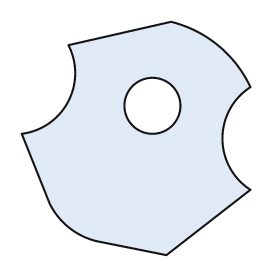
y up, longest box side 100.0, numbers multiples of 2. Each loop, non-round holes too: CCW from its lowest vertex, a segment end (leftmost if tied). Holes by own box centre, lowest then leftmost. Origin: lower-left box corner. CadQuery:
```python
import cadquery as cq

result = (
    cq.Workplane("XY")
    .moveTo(62.0, 0.0)
    .lineTo(98.0, 28.0)
    .threePointArc((86.0, 50.0), (98.0, 72.0))
    .threePointArc((84.0, 90.0), (64.0, 100.0))
    .lineTo(20.0, 90.0)
    .threePointArc((20.0, 66.0), (0.0, 52.0))
    .lineTo(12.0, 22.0)
    .threePointArc((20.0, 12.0), (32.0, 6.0))
    .close()
    .moveTo(56.0, 64.0)
    .circle(12.0)
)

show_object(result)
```